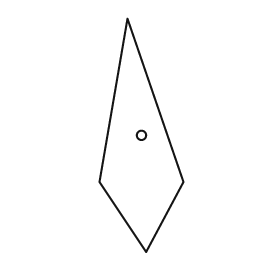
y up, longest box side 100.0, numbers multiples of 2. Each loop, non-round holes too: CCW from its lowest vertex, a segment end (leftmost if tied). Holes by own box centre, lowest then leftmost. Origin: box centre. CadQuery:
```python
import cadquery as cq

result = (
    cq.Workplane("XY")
    .moveTo(2.0, -50.0)
    .lineTo(18.0, -20.0)
    .lineTo(-6.0, 50.0)
    .lineTo(-18.0, -20.0)
    .close()
    .moveTo(0.0, 0.0)
    .circle(2.0)
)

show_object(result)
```